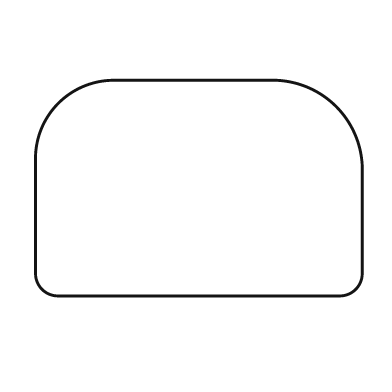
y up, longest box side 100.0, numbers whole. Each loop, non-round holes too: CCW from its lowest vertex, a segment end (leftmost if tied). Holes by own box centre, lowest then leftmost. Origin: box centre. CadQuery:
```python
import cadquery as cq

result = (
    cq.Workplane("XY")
    .moveTo(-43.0, -33.0)
    .lineTo(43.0, -33.0)
    .threePointArc((48.0, -31.0), (50.0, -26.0))
    .lineTo(50.0, 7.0)
    .threePointArc((42.0, 25.0), (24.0, 33.0))
    .lineTo(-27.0, 33.0)
    .threePointArc((-43.0, 26.0), (-50.0, 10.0))
    .lineTo(-50.0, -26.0)
    .threePointArc((-48.0, -31.0), (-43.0, -33.0))
    .close()
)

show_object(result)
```